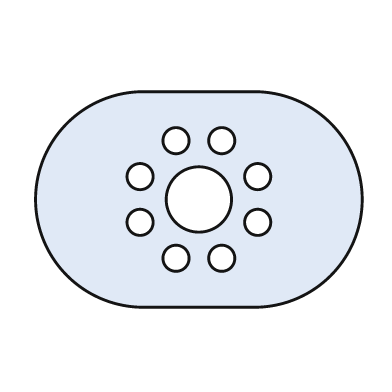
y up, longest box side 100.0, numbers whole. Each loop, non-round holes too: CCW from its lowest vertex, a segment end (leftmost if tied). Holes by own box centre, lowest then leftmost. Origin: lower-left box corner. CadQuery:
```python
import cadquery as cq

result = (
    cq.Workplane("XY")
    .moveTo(33.0, 0.0)
    .lineTo(67.0, 0.0)
    .threePointArc((100.0, 33.0), (67.0, 66.0))
    .lineTo(33.0, 66.0)
    .threePointArc((0.0, 33.0), (33.0, 0.0))
    .close()
    .moveTo(43.0, 15.0)
    .circle(4.0)
    .moveTo(57.0, 15.0)
    .circle(4.0)
    .moveTo(32.0, 26.0)
    .circle(4.0)
    .moveTo(68.0, 26.0)
    .circle(4.0)
    .moveTo(50.0, 33.0)
    .circle(10.0)
    .moveTo(32.0, 40.0)
    .circle(4.0)
    .moveTo(68.0, 40.0)
    .circle(4.0)
    .moveTo(43.0, 51.0)
    .circle(4.0)
    .moveTo(57.0, 51.0)
    .circle(4.0)
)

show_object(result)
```